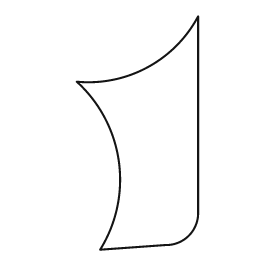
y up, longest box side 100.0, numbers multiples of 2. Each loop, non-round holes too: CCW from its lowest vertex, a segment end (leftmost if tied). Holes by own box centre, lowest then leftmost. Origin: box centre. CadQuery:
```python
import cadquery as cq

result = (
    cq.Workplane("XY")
    .moveTo(-16.0, -50.0)
    .lineTo(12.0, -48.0)
    .threePointArc((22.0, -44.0), (26.0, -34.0))
    .lineTo(26.0, 50.0)
    .threePointArc((4.0, 28.0), (-26.0, 22.0))
    .threePointArc((-8.0, -12.0), (-16.0, -50.0))
    .close()
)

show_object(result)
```